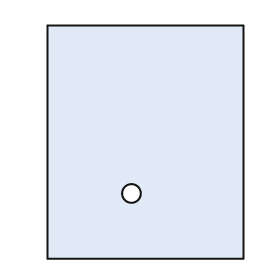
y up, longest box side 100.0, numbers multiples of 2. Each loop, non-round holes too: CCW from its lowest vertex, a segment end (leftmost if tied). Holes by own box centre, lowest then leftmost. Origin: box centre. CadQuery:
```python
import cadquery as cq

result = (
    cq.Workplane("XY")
    .moveTo(-42.0, -50.0)
    .lineTo(42.0, -50.0)
    .lineTo(42.0, 50.0)
    .lineTo(-42.0, 50.0)
    .close()
    .moveTo(-6.0, -22.0)
    .circle(4.0)
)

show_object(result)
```